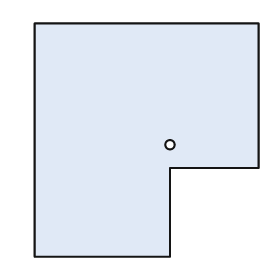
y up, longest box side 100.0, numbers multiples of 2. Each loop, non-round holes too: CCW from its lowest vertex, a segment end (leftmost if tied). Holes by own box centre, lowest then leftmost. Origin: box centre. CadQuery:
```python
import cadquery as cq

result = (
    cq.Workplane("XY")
    .moveTo(-48.0, -50.0)
    .lineTo(10.0, -50.0)
    .lineTo(10.0, -12.0)
    .lineTo(48.0, -12.0)
    .lineTo(48.0, 50.0)
    .lineTo(-48.0, 50.0)
    .close()
    .moveTo(10.0, -2.0)
    .circle(2.0)
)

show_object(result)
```